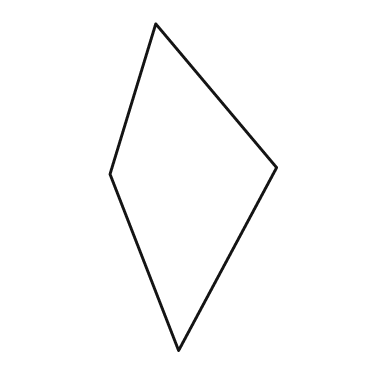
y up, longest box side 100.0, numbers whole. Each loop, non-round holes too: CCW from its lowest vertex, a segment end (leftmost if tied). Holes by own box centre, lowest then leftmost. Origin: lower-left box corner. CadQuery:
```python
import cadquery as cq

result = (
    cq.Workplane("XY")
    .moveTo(21.0, 0.0)
    .lineTo(51.0, 56.0)
    .lineTo(14.0, 100.0)
    .lineTo(0.0, 54.0)
    .close()
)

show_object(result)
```